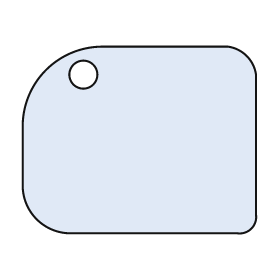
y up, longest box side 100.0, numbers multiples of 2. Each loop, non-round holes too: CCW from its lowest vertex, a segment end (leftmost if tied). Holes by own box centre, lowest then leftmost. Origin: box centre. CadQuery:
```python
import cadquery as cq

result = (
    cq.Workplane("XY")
    .moveTo(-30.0, -40.0)
    .lineTo(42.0, -40.0)
    .threePointArc((48.0, -38.0), (50.0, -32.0))
    .lineTo(50.0, 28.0)
    .threePointArc((46.0, 36.0), (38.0, 40.0))
    .lineTo(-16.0, 40.0)
    .threePointArc((-40.0, 30.0), (-50.0, 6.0))
    .lineTo(-50.0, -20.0)
    .threePointArc((-44.0, -34.0), (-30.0, -40.0))
    .close()
    .moveTo(-24.0, 28.0)
    .circle(6.0)
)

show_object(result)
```